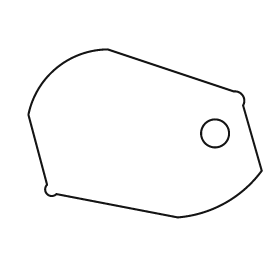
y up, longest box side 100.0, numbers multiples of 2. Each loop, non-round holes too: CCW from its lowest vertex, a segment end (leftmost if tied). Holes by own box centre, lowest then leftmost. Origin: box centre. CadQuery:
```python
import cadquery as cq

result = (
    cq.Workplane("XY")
    .moveTo(14.0, -36.0)
    .threePointArc((34.0, -30.0), (50.0, -16.0))
    .lineTo(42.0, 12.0)
    .threePointArc((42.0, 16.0), (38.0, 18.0))
    .lineTo(-16.0, 36.0)
    .threePointArc((-38.0, 28.0), (-50.0, 8.0))
    .lineTo(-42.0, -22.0)
    .threePointArc((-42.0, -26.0), (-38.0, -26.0))
    .close()
    .moveTo(30.0, 0.0)
    .circle(6.0)
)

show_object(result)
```